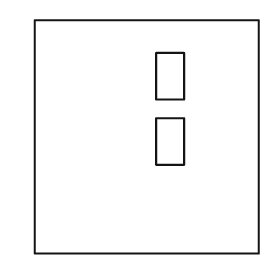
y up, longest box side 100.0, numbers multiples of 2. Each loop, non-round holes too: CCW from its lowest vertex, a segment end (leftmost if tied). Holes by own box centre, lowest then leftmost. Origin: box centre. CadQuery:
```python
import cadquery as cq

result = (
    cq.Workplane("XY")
    .moveTo(-48.0, -50.0)
    .lineTo(48.0, -50.0)
    .lineTo(48.0, 50.0)
    .lineTo(-48.0, 50.0)
    .close()
    .moveTo(4.0, -12.0)
    .lineTo(16.0, -12.0)
    .lineTo(16.0, 8.0)
    .lineTo(4.0, 8.0)
    .close()
    .moveTo(4.0, 16.0)
    .lineTo(16.0, 16.0)
    .lineTo(16.0, 36.0)
    .lineTo(4.0, 36.0)
    .close()
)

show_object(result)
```